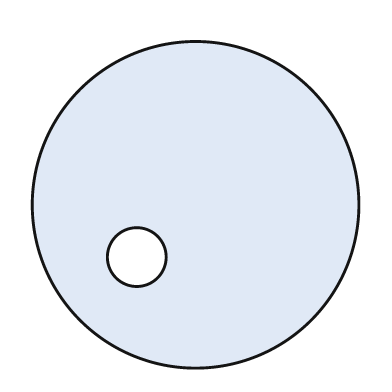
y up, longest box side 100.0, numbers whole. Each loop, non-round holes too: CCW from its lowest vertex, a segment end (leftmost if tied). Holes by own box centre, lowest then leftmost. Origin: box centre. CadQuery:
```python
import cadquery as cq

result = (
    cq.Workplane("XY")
    .moveTo(0.0, 0.0)
    .circle(50.0)
    .moveTo(-18.0, -16.0)
    .circle(9.0)
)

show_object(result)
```